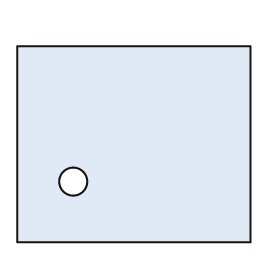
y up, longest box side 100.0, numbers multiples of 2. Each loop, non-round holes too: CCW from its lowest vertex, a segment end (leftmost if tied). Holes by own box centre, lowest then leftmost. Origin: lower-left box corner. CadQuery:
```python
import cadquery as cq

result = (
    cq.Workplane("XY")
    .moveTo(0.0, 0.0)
    .lineTo(100.0, 0.0)
    .lineTo(100.0, 84.0)
    .lineTo(0.0, 84.0)
    .close()
    .moveTo(24.0, 26.0)
    .circle(6.0)
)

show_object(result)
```